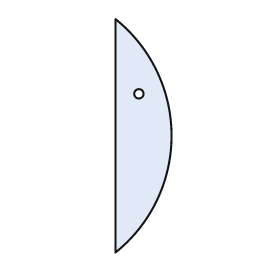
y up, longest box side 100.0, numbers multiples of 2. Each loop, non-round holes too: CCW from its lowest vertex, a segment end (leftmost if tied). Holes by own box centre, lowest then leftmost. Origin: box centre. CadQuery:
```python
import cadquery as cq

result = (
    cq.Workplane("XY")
    .moveTo(-12.0, -50.0)
    .threePointArc((12.0, 0.0), (-12.0, 50.0))
    .close()
    .moveTo(-2.0, 18.0)
    .circle(2.0)
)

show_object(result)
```